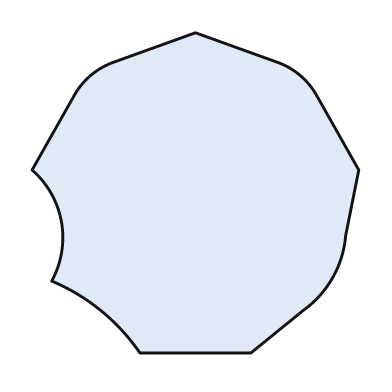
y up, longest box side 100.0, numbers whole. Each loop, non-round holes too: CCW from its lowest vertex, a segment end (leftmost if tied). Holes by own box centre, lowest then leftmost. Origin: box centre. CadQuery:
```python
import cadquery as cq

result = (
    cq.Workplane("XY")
    .moveTo(-17.0, -49.0)
    .lineTo(17.0, -49.0)
    .lineTo(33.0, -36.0)
    .threePointArc((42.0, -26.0), (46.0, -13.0))
    .lineTo(50.0, 7.0)
    .lineTo(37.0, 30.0)
    .threePointArc((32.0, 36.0), (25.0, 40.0))
    .lineTo(0.0, 49.0)
    .lineTo(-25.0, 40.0)
    .threePointArc((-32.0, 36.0), (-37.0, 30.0))
    .lineTo(-50.0, 7.0)
    .threePointArc((-41.0, -9.0), (-44.0, -27.0))
    .threePointArc((-29.0, -36.0), (-17.0, -49.0))
    .close()
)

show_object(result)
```